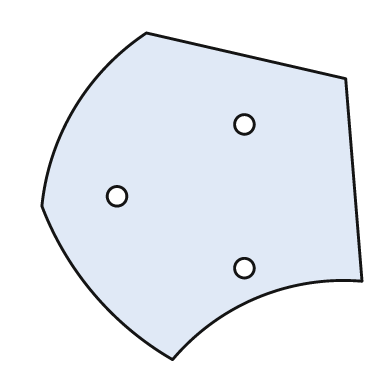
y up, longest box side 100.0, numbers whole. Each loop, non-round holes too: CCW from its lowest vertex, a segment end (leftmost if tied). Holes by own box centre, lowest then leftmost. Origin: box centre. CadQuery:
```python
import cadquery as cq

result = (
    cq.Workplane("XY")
    .moveTo(-9.0, -50.0)
    .threePointArc((17.0, -31.0), (49.0, -26.0))
    .lineTo(44.0, 36.0)
    .lineTo(-17.0, 50.0)
    .threePointArc((-39.0, 27.0), (-49.0, -3.0))
    .threePointArc((-33.0, -30.0), (-9.0, -50.0))
    .close()
    .moveTo(13.0, -22.0)
    .circle(3.0)
    .moveTo(-26.0, 0.0)
    .circle(3.0)
    .moveTo(13.0, 22.0)
    .circle(3.0)
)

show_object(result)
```